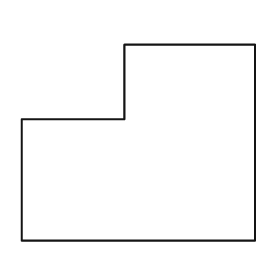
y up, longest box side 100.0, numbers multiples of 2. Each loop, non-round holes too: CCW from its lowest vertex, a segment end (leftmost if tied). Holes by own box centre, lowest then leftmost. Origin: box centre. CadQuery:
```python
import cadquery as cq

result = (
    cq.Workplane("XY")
    .moveTo(-50.0, -42.0)
    .lineTo(50.0, -42.0)
    .lineTo(50.0, 42.0)
    .lineTo(-6.0, 42.0)
    .lineTo(-6.0, 10.0)
    .lineTo(-50.0, 10.0)
    .close()
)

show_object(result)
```